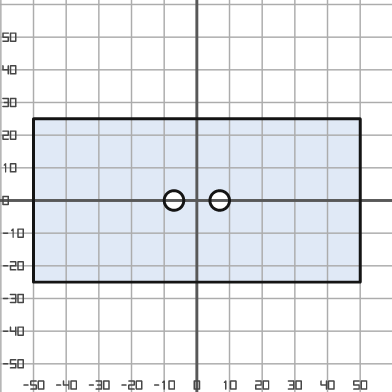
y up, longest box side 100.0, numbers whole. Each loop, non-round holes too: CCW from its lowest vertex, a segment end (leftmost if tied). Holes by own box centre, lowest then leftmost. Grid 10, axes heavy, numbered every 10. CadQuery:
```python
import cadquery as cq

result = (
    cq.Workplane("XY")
    .moveTo(-50.0, -25.0)
    .lineTo(50.0, -25.0)
    .lineTo(50.0, 25.0)
    .lineTo(-50.0, 25.0)
    .close()
    .moveTo(-7.0, 0.0)
    .circle(3.0)
    .moveTo(7.0, 0.0)
    .circle(3.0)
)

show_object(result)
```